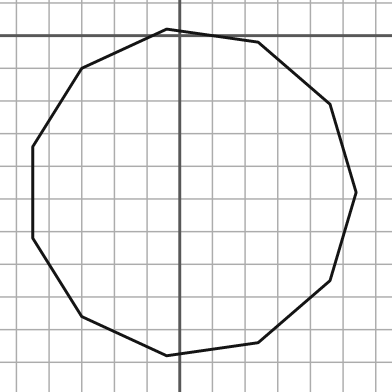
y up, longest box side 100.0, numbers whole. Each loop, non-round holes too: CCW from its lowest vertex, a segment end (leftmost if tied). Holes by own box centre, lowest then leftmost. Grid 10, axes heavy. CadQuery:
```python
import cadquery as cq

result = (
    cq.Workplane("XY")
    .moveTo(-4.0, -98.0)
    .lineTo(24.0, -94.0)
    .lineTo(46.0, -75.0)
    .lineTo(54.0, -48.0)
    .lineTo(46.0, -21.0)
    .lineTo(24.0, -2.0)
    .lineTo(-4.0, 2.0)
    .lineTo(-30.0, -10.0)
    .lineTo(-45.0, -34.0)
    .lineTo(-45.0, -62.0)
    .lineTo(-30.0, -86.0)
    .close()
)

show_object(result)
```